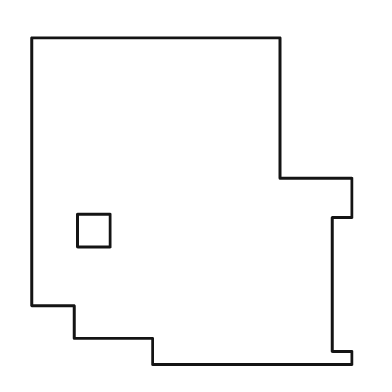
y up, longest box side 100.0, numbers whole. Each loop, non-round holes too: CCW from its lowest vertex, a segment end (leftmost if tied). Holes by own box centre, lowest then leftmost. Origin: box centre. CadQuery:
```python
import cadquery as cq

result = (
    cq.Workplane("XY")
    .moveTo(-12.0, -50.0)
    .lineTo(49.0, -50.0)
    .lineTo(49.0, -46.0)
    .lineTo(43.0, -46.0)
    .lineTo(43.0, -5.0)
    .lineTo(49.0, -5.0)
    .lineTo(49.0, 7.0)
    .lineTo(27.0, 7.0)
    .lineTo(27.0, 50.0)
    .lineTo(-49.0, 50.0)
    .lineTo(-49.0, -32.0)
    .lineTo(-36.0, -32.0)
    .lineTo(-36.0, -42.0)
    .lineTo(-12.0, -42.0)
    .close()
    .moveTo(-35.0, -14.0)
    .lineTo(-25.0, -14.0)
    .lineTo(-25.0, -4.0)
    .lineTo(-35.0, -4.0)
    .close()
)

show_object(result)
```